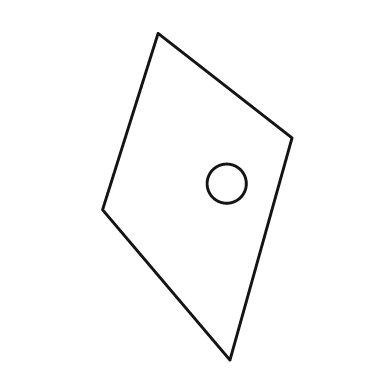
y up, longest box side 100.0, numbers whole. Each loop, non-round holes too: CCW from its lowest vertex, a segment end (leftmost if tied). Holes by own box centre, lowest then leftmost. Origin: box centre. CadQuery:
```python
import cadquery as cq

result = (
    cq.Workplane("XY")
    .moveTo(10.0, -50.0)
    .lineTo(29.0, 18.0)
    .lineTo(-12.0, 50.0)
    .lineTo(-29.0, -4.0)
    .close()
    .moveTo(9.0, 4.0)
    .circle(6.0)
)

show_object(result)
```